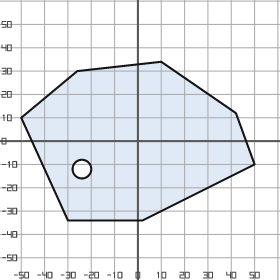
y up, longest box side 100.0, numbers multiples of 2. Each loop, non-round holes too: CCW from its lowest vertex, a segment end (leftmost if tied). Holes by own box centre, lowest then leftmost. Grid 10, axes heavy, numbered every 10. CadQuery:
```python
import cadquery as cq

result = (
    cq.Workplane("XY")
    .moveTo(-30.0, -34.0)
    .lineTo(2.0, -34.0)
    .lineTo(50.0, -10.0)
    .lineTo(42.0, 12.0)
    .lineTo(10.0, 34.0)
    .lineTo(-26.0, 30.0)
    .lineTo(-50.0, 10.0)
    .close()
    .moveTo(-24.0, -12.0)
    .circle(4.0)
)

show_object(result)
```